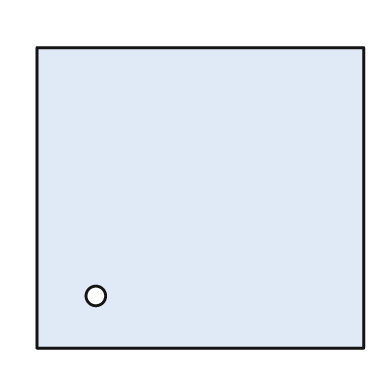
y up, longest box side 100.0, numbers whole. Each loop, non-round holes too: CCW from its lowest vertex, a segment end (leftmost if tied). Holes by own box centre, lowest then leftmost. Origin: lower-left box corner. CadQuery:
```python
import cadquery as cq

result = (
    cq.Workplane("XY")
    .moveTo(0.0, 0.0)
    .lineTo(100.0, 0.0)
    .lineTo(100.0, 92.0)
    .lineTo(0.0, 92.0)
    .close()
    .moveTo(18.0, 16.0)
    .circle(3.0)
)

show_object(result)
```